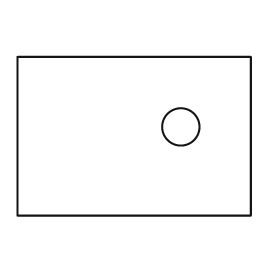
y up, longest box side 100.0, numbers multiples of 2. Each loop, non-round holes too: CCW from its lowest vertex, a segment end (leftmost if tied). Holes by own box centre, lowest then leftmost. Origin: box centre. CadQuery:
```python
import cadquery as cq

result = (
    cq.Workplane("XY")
    .moveTo(-50.0, -34.0)
    .lineTo(50.0, -34.0)
    .lineTo(50.0, 34.0)
    .lineTo(-50.0, 34.0)
    .close()
    .moveTo(20.0, 4.0)
    .circle(8.0)
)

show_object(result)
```